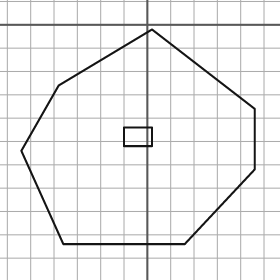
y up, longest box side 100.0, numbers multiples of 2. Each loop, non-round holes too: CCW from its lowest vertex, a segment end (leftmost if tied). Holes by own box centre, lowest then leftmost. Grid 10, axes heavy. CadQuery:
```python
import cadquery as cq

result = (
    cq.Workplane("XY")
    .moveTo(-36.0, -94.0)
    .lineTo(16.0, -94.0)
    .lineTo(46.0, -62.0)
    .lineTo(46.0, -36.0)
    .lineTo(2.0, -2.0)
    .lineTo(-38.0, -26.0)
    .lineTo(-54.0, -54.0)
    .close()
    .moveTo(-10.0, -52.0)
    .lineTo(2.0, -52.0)
    .lineTo(2.0, -44.0)
    .lineTo(-10.0, -44.0)
    .close()
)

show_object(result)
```